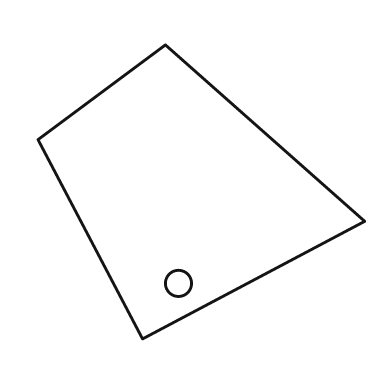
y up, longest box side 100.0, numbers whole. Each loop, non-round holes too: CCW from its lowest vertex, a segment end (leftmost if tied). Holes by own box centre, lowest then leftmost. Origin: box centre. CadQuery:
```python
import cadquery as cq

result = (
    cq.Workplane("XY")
    .moveTo(-18.0, -45.0)
    .lineTo(50.0, -9.0)
    .lineTo(-11.0, 45.0)
    .lineTo(-50.0, 16.0)
    .close()
    .moveTo(-7.0, -28.0)
    .circle(4.0)
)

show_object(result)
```